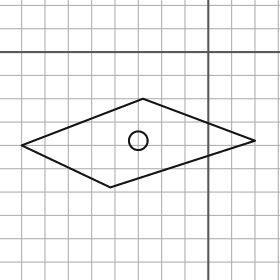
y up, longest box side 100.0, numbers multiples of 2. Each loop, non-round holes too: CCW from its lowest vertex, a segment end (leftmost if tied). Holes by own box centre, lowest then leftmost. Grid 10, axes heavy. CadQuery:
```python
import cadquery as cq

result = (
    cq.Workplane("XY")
    .moveTo(-42.0, -58.0)
    .lineTo(20.0, -38.0)
    .lineTo(-28.0, -20.0)
    .lineTo(-80.0, -40.0)
    .close()
    .moveTo(-30.0, -38.0)
    .circle(4.0)
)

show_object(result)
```